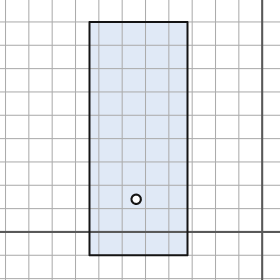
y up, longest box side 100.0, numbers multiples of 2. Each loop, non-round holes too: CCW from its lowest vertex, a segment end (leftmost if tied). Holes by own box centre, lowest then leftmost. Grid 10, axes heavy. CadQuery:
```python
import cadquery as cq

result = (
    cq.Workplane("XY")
    .moveTo(-74.0, -10.0)
    .lineTo(-32.0, -10.0)
    .lineTo(-32.0, 90.0)
    .lineTo(-74.0, 90.0)
    .close()
    .moveTo(-54.0, 14.0)
    .circle(2.0)
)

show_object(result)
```